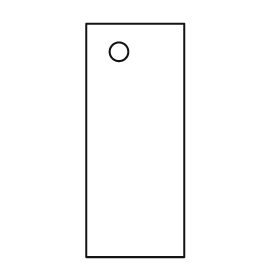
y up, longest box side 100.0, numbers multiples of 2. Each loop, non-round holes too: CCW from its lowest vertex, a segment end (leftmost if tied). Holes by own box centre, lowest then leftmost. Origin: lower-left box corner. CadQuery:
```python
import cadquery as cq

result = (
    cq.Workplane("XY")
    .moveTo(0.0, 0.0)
    .lineTo(42.0, 0.0)
    .lineTo(42.0, 100.0)
    .lineTo(0.0, 100.0)
    .close()
    .moveTo(14.0, 88.0)
    .circle(4.0)
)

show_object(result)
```